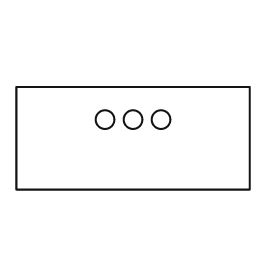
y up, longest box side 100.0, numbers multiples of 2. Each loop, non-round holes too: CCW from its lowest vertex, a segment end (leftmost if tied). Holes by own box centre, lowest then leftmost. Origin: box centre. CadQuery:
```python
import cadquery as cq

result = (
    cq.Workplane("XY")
    .moveTo(-50.0, -22.0)
    .lineTo(50.0, -22.0)
    .lineTo(50.0, 22.0)
    .lineTo(-50.0, 22.0)
    .close()
    .moveTo(-12.0, 8.0)
    .circle(4.0)
    .moveTo(0.0, 8.0)
    .circle(4.0)
    .moveTo(12.0, 8.0)
    .circle(4.0)
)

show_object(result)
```